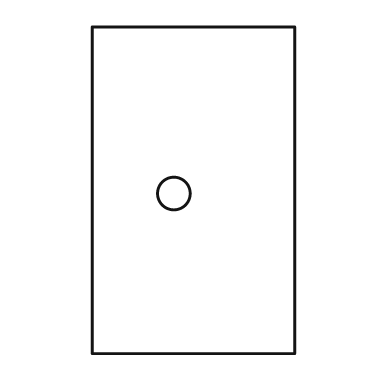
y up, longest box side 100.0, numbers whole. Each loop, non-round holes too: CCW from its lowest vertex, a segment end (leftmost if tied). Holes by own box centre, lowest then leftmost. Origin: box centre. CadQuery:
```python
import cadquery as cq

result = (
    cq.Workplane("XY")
    .moveTo(-31.0, -50.0)
    .lineTo(31.0, -50.0)
    .lineTo(31.0, 50.0)
    .lineTo(-31.0, 50.0)
    .close()
    .moveTo(-6.0, -1.0)
    .circle(5.0)
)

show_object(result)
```